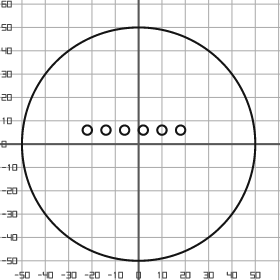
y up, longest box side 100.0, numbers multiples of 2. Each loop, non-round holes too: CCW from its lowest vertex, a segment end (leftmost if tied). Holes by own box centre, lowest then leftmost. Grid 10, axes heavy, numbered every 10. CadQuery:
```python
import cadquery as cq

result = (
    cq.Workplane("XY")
    .moveTo(0.0, 0.0)
    .circle(50.0)
    .moveTo(-22.0, 6.0)
    .circle(2.0)
    .moveTo(-14.0, 6.0)
    .circle(2.0)
    .moveTo(-6.0, 6.0)
    .circle(2.0)
    .moveTo(2.0, 6.0)
    .circle(2.0)
    .moveTo(10.0, 6.0)
    .circle(2.0)
    .moveTo(18.0, 6.0)
    .circle(2.0)
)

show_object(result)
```